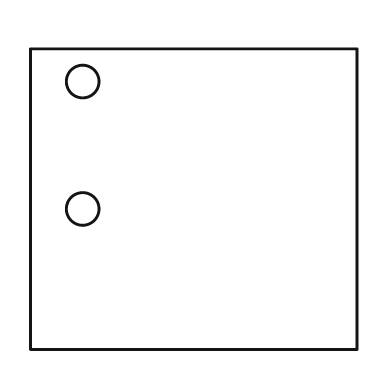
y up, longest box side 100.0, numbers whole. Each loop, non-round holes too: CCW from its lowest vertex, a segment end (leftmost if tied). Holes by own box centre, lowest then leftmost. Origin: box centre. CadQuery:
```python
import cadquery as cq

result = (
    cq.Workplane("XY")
    .moveTo(-50.0, -46.0)
    .lineTo(50.0, -46.0)
    .lineTo(50.0, 46.0)
    .lineTo(-50.0, 46.0)
    .close()
    .moveTo(-34.0, -3.0)
    .circle(5.0)
    .moveTo(-34.0, 36.0)
    .circle(5.0)
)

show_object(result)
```